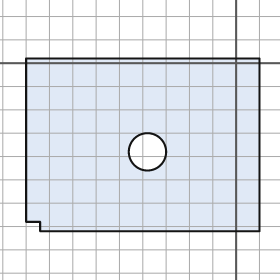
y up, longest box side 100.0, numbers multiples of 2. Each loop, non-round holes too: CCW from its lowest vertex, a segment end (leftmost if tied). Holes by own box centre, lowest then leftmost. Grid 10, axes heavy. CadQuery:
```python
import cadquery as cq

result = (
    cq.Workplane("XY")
    .moveTo(-84.0, -72.0)
    .lineTo(10.0, -72.0)
    .lineTo(10.0, 2.0)
    .lineTo(-90.0, 2.0)
    .lineTo(-90.0, -68.0)
    .lineTo(-84.0, -68.0)
    .close()
    .moveTo(-38.0, -38.0)
    .circle(8.0)
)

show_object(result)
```